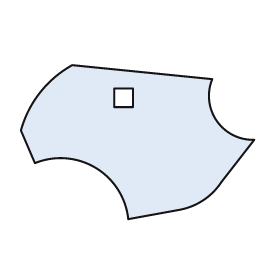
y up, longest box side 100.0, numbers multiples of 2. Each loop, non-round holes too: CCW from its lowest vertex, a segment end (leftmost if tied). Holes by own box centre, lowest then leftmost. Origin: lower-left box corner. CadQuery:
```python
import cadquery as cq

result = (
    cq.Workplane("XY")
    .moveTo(46.0, 0.0)
    .lineTo(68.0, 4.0)
    .threePointArc((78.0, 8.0), (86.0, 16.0))
    .lineTo(100.0, 34.0)
    .threePointArc((84.0, 42.0), (82.0, 60.0))
    .lineTo(22.0, 66.0)
    .threePointArc((8.0, 54.0), (0.0, 38.0))
    .lineTo(6.0, 24.0)
    .threePointArc((32.0, 22.0), (46.0, 0.0))
    .close()
    .moveTo(40.0, 48.0)
    .lineTo(48.0, 48.0)
    .lineTo(48.0, 56.0)
    .lineTo(40.0, 56.0)
    .close()
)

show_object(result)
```